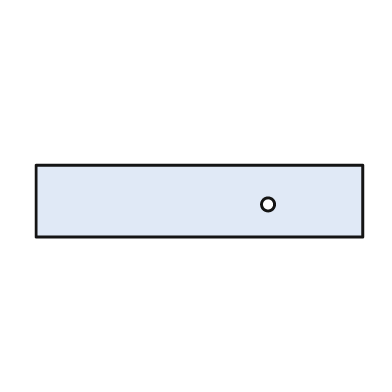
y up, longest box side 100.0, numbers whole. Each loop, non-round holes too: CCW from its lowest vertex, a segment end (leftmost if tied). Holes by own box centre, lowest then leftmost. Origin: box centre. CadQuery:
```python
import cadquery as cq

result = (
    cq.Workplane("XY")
    .moveTo(-50.0, -11.0)
    .lineTo(50.0, -11.0)
    .lineTo(50.0, 11.0)
    .lineTo(-50.0, 11.0)
    .close()
    .moveTo(21.0, -1.0)
    .circle(2.0)
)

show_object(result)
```